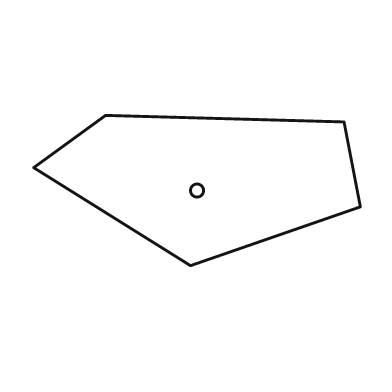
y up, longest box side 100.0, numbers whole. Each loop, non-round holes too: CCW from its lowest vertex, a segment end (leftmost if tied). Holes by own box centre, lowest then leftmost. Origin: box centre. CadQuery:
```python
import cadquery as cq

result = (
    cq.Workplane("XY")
    .moveTo(-2.0, -23.0)
    .lineTo(50.0, -5.0)
    .lineTo(45.0, 21.0)
    .lineTo(-28.0, 23.0)
    .lineTo(-50.0, 7.0)
    .close()
    .moveTo(0.0, 0.0)
    .circle(2.0)
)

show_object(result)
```